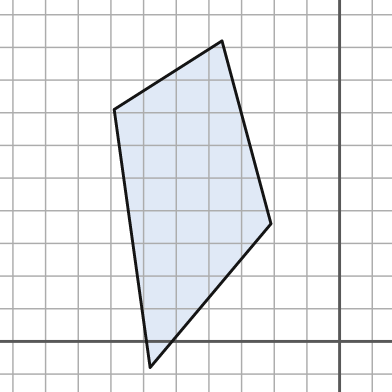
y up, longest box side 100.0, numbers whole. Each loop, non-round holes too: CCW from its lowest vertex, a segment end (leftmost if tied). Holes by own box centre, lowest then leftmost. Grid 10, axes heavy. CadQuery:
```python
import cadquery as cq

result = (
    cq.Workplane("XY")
    .moveTo(-58.0, -8.0)
    .lineTo(-21.0, 36.0)
    .lineTo(-36.0, 92.0)
    .lineTo(-69.0, 71.0)
    .close()
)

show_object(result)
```